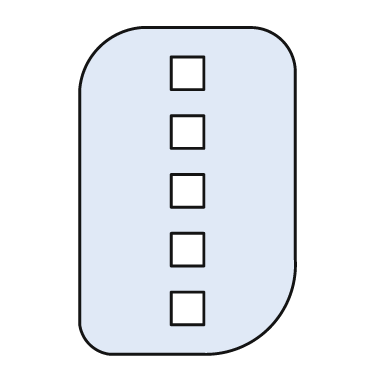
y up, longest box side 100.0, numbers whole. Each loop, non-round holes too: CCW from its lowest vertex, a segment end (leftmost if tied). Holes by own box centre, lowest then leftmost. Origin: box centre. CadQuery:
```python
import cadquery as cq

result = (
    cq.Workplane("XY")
    .moveTo(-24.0, -50.0)
    .lineTo(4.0, -50.0)
    .threePointArc((25.0, -42.0), (33.0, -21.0))
    .lineTo(33.0, 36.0)
    .threePointArc((29.0, 46.0), (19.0, 50.0))
    .lineTo(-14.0, 50.0)
    .threePointArc((-27.0, 44.0), (-33.0, 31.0))
    .lineTo(-33.0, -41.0)
    .threePointArc((-30.0, -47.0), (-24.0, -50.0))
    .close()
    .moveTo(-5.0, -41.0)
    .lineTo(5.0, -41.0)
    .lineTo(5.0, -31.0)
    .lineTo(-5.0, -31.0)
    .close()
    .moveTo(-5.0, -23.0)
    .lineTo(5.0, -23.0)
    .lineTo(5.0, -13.0)
    .lineTo(-5.0, -13.0)
    .close()
    .moveTo(-5.0, -5.0)
    .lineTo(5.0, -5.0)
    .lineTo(5.0, 5.0)
    .lineTo(-5.0, 5.0)
    .close()
    .moveTo(-5.0, 13.0)
    .lineTo(5.0, 13.0)
    .lineTo(5.0, 23.0)
    .lineTo(-5.0, 23.0)
    .close()
    .moveTo(-5.0, 31.0)
    .lineTo(5.0, 31.0)
    .lineTo(5.0, 41.0)
    .lineTo(-5.0, 41.0)
    .close()
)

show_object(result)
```